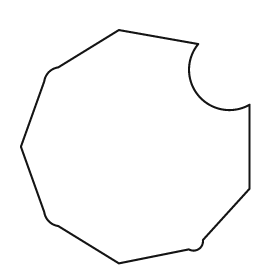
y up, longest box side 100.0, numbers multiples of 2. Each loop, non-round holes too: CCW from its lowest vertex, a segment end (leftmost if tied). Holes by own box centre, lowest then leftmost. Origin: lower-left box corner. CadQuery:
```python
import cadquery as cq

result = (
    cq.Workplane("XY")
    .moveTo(42.0, 0.0)
    .lineTo(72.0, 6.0)
    .threePointArc((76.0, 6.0), (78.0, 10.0))
    .lineTo(98.0, 32.0)
    .lineTo(98.0, 68.0)
    .threePointArc((76.0, 72.0), (76.0, 94.0))
    .lineTo(42.0, 100.0)
    .lineTo(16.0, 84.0)
    .threePointArc((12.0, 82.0), (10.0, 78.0))
    .lineTo(0.0, 50.0)
    .lineTo(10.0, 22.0)
    .threePointArc((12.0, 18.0), (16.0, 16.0))
    .close()
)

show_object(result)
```